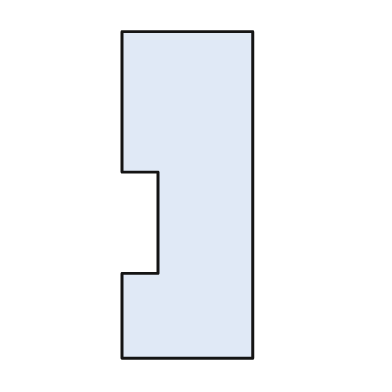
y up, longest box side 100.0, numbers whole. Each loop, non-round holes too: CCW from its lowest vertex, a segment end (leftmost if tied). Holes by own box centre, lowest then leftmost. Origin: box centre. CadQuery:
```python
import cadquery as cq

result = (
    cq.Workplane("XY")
    .moveTo(-20.0, -50.0)
    .lineTo(20.0, -50.0)
    .lineTo(20.0, 50.0)
    .lineTo(-20.0, 50.0)
    .lineTo(-20.0, 7.0)
    .lineTo(-9.0, 7.0)
    .lineTo(-9.0, -24.0)
    .lineTo(-20.0, -24.0)
    .close()
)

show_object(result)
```